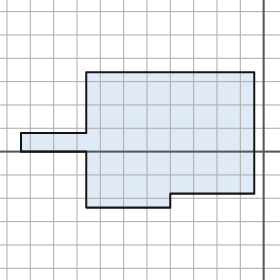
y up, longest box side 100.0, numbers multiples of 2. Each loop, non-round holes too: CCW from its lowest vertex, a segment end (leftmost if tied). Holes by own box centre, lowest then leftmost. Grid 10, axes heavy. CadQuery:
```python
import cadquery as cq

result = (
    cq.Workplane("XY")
    .moveTo(-76.0, -24.0)
    .lineTo(-40.0, -24.0)
    .lineTo(-40.0, -18.0)
    .lineTo(-4.0, -18.0)
    .lineTo(-4.0, 34.0)
    .lineTo(-76.0, 34.0)
    .lineTo(-76.0, 8.0)
    .lineTo(-104.0, 8.0)
    .lineTo(-104.0, 0.0)
    .lineTo(-76.0, 0.0)
    .close()
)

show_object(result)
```